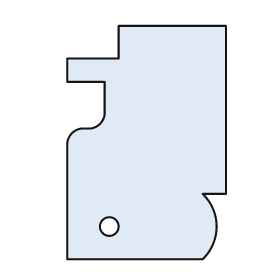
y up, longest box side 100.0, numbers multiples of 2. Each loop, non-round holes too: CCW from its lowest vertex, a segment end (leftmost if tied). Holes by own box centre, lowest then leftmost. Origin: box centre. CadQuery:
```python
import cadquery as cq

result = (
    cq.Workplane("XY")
    .moveTo(-34.0, -50.0)
    .lineTo(24.0, -50.0)
    .threePointArc((30.0, -36.0), (24.0, -22.0))
    .lineTo(34.0, -22.0)
    .lineTo(34.0, 50.0)
    .lineTo(-12.0, 50.0)
    .lineTo(-12.0, 36.0)
    .lineTo(-34.0, 36.0)
    .lineTo(-34.0, 26.0)
    .lineTo(-18.0, 26.0)
    .lineTo(-18.0, 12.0)
    .threePointArc((-20.0, 8.0), (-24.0, 6.0))
    .lineTo(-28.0, 6.0)
    .threePointArc((-32.0, 4.0), (-34.0, 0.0))
    .close()
    .moveTo(-16.0, -36.0)
    .circle(4.0)
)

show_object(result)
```